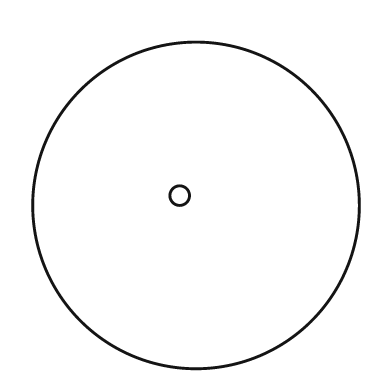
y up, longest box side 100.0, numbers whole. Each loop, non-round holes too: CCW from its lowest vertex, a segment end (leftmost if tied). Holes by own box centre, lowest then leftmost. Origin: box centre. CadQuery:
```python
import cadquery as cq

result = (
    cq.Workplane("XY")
    .moveTo(0.0, 0.0)
    .circle(50.0)
    .moveTo(-5.0, 3.0)
    .circle(3.0)
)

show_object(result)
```